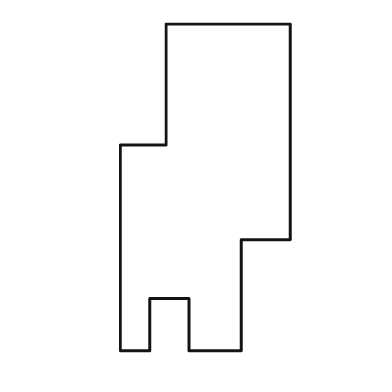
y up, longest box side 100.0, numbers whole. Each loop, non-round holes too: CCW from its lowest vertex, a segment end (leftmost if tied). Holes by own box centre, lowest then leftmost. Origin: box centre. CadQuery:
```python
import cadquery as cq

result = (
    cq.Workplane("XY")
    .moveTo(-26.0, -50.0)
    .lineTo(-17.0, -50.0)
    .lineTo(-17.0, -34.0)
    .lineTo(-5.0, -34.0)
    .lineTo(-5.0, -50.0)
    .lineTo(11.0, -50.0)
    .lineTo(11.0, -16.0)
    .lineTo(26.0, -16.0)
    .lineTo(26.0, 50.0)
    .lineTo(-12.0, 50.0)
    .lineTo(-12.0, 13.0)
    .lineTo(-26.0, 13.0)
    .close()
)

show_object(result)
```